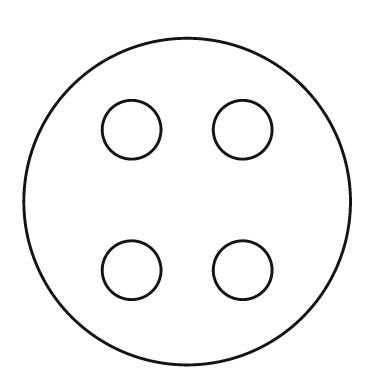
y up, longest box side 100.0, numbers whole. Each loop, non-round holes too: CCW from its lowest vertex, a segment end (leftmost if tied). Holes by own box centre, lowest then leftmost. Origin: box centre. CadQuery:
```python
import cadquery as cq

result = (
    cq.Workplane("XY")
    .moveTo(0.0, 0.0)
    .circle(50.0)
    .moveTo(-17.0, -21.0)
    .circle(9.0)
    .moveTo(17.0, -21.0)
    .circle(9.0)
    .moveTo(-17.0, 22.0)
    .circle(9.0)
    .moveTo(17.0, 22.0)
    .circle(9.0)
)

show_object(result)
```